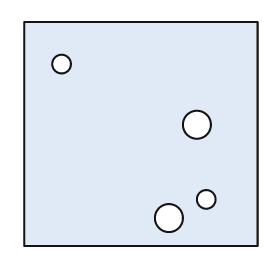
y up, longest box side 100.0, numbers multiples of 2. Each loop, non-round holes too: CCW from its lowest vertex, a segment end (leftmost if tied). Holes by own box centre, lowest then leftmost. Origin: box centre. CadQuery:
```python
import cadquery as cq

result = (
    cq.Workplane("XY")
    .moveTo(-50.0, -48.0)
    .lineTo(50.0, -48.0)
    .lineTo(50.0, 48.0)
    .lineTo(-50.0, 48.0)
    .close()
    .moveTo(12.0, -36.0)
    .circle(6.0)
    .moveTo(28.0, -28.0)
    .circle(4.0)
    .moveTo(24.0, 4.0)
    .circle(6.0)
    .moveTo(-34.0, 30.0)
    .circle(4.0)
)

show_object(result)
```